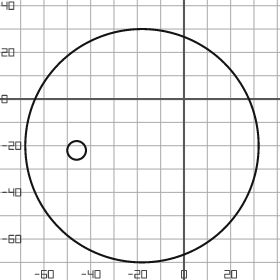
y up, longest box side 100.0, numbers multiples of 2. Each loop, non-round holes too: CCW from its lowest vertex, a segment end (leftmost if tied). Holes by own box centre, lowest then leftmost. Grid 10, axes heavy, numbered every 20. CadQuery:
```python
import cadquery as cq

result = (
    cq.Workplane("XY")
    .moveTo(-18.0, -20.0)
    .circle(50.0)
    .moveTo(-46.0, -22.0)
    .circle(4.0)
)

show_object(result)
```